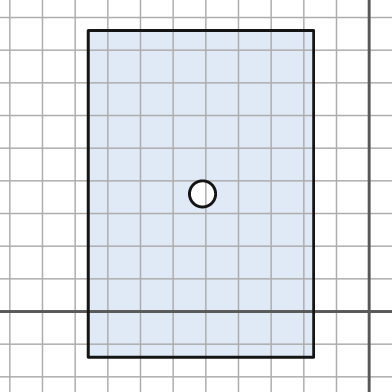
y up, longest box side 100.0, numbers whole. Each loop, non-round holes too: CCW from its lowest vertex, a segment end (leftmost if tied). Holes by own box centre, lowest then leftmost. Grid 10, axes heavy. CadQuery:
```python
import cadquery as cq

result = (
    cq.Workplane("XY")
    .moveTo(-86.0, -14.0)
    .lineTo(-17.0, -14.0)
    .lineTo(-17.0, 86.0)
    .lineTo(-86.0, 86.0)
    .close()
    .moveTo(-51.0, 36.0)
    .circle(4.0)
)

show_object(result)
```